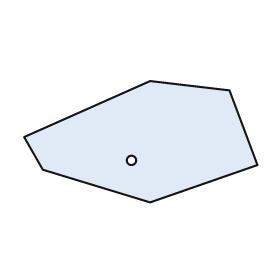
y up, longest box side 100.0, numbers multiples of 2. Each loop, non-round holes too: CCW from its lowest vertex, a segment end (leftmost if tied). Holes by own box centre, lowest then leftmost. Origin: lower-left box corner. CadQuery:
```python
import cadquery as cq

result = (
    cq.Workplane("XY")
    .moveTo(54.0, 0.0)
    .lineTo(100.0, 16.0)
    .lineTo(88.0, 48.0)
    .lineTo(54.0, 52.0)
    .lineTo(0.0, 28.0)
    .lineTo(8.0, 14.0)
    .close()
    .moveTo(46.0, 18.0)
    .circle(2.0)
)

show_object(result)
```